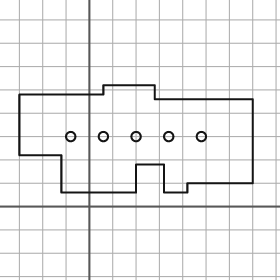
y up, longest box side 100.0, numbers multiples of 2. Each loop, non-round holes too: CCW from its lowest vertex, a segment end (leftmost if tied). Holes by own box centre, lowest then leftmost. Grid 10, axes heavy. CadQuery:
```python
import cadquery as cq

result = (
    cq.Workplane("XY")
    .moveTo(-12.0, 6.0)
    .lineTo(20.0, 6.0)
    .lineTo(20.0, 18.0)
    .lineTo(32.0, 18.0)
    .lineTo(32.0, 6.0)
    .lineTo(42.0, 6.0)
    .lineTo(42.0, 10.0)
    .lineTo(70.0, 10.0)
    .lineTo(70.0, 46.0)
    .lineTo(28.0, 46.0)
    .lineTo(28.0, 52.0)
    .lineTo(6.0, 52.0)
    .lineTo(6.0, 48.0)
    .lineTo(-30.0, 48.0)
    .lineTo(-30.0, 22.0)
    .lineTo(-12.0, 22.0)
    .close()
    .moveTo(-8.0, 30.0)
    .circle(2.0)
    .moveTo(6.0, 30.0)
    .circle(2.0)
    .moveTo(20.0, 30.0)
    .circle(2.0)
    .moveTo(34.0, 30.0)
    .circle(2.0)
    .moveTo(48.0, 30.0)
    .circle(2.0)
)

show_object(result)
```